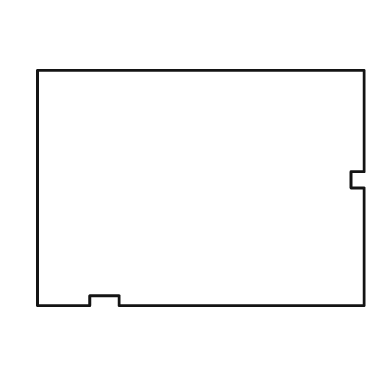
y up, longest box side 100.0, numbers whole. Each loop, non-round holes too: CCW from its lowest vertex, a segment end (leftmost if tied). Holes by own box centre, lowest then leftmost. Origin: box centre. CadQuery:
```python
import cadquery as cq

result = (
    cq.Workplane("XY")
    .moveTo(-50.0, -36.0)
    .lineTo(-34.0, -36.0)
    .lineTo(-34.0, -33.0)
    .lineTo(-25.0, -33.0)
    .lineTo(-25.0, -36.0)
    .lineTo(50.0, -36.0)
    .lineTo(50.0, 0.0)
    .lineTo(46.0, 0.0)
    .lineTo(46.0, 5.0)
    .lineTo(50.0, 5.0)
    .lineTo(50.0, 36.0)
    .lineTo(-50.0, 36.0)
    .close()
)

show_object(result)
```